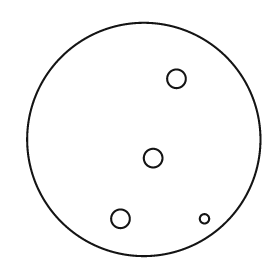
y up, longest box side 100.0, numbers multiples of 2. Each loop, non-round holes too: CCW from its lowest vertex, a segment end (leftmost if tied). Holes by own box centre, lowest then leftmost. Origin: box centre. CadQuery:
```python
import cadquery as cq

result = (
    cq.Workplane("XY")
    .moveTo(0.0, 0.0)
    .circle(50.0)
    .moveTo(-10.0, -34.0)
    .circle(4.0)
    .moveTo(26.0, -34.0)
    .circle(2.0)
    .moveTo(4.0, -8.0)
    .circle(4.0)
    .moveTo(14.0, 26.0)
    .circle(4.0)
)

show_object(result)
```